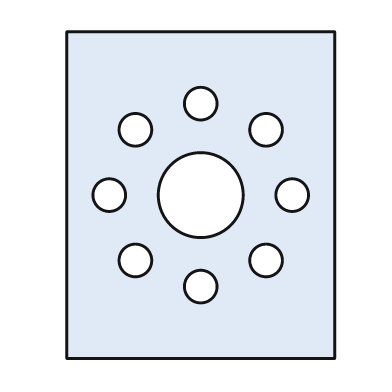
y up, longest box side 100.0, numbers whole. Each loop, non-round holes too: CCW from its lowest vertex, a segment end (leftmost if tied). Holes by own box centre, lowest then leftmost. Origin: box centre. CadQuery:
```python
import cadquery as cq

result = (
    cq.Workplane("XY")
    .moveTo(-41.0, -50.0)
    .lineTo(41.0, -50.0)
    .lineTo(41.0, 50.0)
    .lineTo(-41.0, 50.0)
    .close()
    .moveTo(0.0, -28.0)
    .circle(5.0)
    .moveTo(-20.0, -20.0)
    .circle(5.0)
    .moveTo(20.0, -20.0)
    .circle(5.0)
    .moveTo(-28.0, 0.0)
    .circle(5.0)
    .moveTo(0.0, 0.0)
    .circle(13.0)
    .moveTo(28.0, 0.0)
    .circle(5.0)
    .moveTo(-20.0, 20.0)
    .circle(5.0)
    .moveTo(20.0, 20.0)
    .circle(5.0)
    .moveTo(0.0, 28.0)
    .circle(5.0)
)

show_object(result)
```